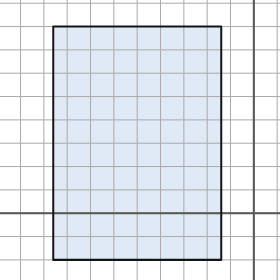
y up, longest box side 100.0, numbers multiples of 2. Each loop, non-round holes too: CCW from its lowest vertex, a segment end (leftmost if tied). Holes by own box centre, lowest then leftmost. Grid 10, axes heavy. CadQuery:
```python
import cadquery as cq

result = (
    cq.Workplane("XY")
    .moveTo(-86.0, -20.0)
    .lineTo(-14.0, -20.0)
    .lineTo(-14.0, 80.0)
    .lineTo(-86.0, 80.0)
    .close()
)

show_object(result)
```